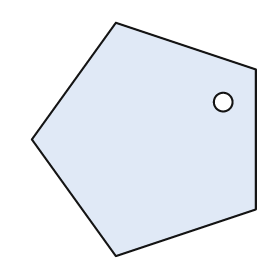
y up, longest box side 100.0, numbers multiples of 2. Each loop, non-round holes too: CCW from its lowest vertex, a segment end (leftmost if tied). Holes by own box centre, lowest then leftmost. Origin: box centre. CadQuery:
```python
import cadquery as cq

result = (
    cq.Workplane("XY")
    .moveTo(-12.0, -50.0)
    .lineTo(48.0, -30.0)
    .lineTo(48.0, 30.0)
    .lineTo(-12.0, 50.0)
    .lineTo(-48.0, 0.0)
    .close()
    .moveTo(34.0, 16.0)
    .circle(4.0)
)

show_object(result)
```